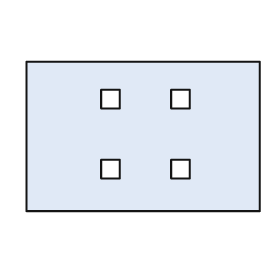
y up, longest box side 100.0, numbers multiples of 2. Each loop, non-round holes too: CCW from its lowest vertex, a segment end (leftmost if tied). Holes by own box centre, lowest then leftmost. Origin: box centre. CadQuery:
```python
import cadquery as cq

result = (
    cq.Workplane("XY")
    .moveTo(-50.0, -32.0)
    .lineTo(50.0, -32.0)
    .lineTo(50.0, 32.0)
    .lineTo(-50.0, 32.0)
    .close()
    .moveTo(-18.0, -18.0)
    .lineTo(-10.0, -18.0)
    .lineTo(-10.0, -10.0)
    .lineTo(-18.0, -10.0)
    .close()
    .moveTo(12.0, -18.0)
    .lineTo(20.0, -18.0)
    .lineTo(20.0, -10.0)
    .lineTo(12.0, -10.0)
    .close()
    .moveTo(-18.0, 12.0)
    .lineTo(-10.0, 12.0)
    .lineTo(-10.0, 20.0)
    .lineTo(-18.0, 20.0)
    .close()
    .moveTo(12.0, 12.0)
    .lineTo(20.0, 12.0)
    .lineTo(20.0, 20.0)
    .lineTo(12.0, 20.0)
    .close()
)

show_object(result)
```